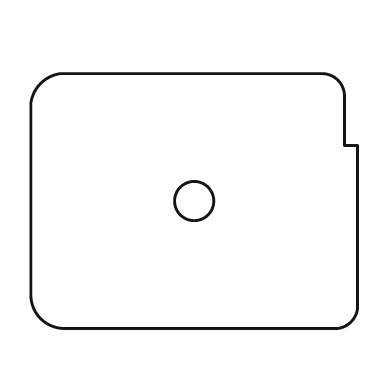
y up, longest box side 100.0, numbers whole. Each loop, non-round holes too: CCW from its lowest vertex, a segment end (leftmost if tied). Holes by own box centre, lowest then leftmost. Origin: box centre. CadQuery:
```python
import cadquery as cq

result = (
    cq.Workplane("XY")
    .moveTo(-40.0, -39.0)
    .lineTo(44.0, -39.0)
    .threePointArc((48.0, -37.0), (50.0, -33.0))
    .lineTo(50.0, 17.0)
    .lineTo(46.0, 17.0)
    .lineTo(46.0, 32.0)
    .threePointArc((44.0, 37.0), (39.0, 39.0))
    .lineTo(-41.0, 39.0)
    .threePointArc((-47.0, 36.0), (-50.0, 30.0))
    .lineTo(-50.0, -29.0)
    .threePointArc((-47.0, -36.0), (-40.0, -39.0))
    .close()
    .moveTo(0.0, 0.0)
    .circle(6.0)
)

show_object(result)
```